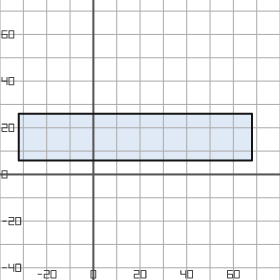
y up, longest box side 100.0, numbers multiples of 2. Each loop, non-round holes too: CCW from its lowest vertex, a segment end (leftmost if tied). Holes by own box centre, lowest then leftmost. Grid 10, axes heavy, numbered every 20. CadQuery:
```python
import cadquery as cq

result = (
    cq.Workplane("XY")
    .moveTo(-32.0, 6.0)
    .lineTo(68.0, 6.0)
    .lineTo(68.0, 26.0)
    .lineTo(-32.0, 26.0)
    .close()
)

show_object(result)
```